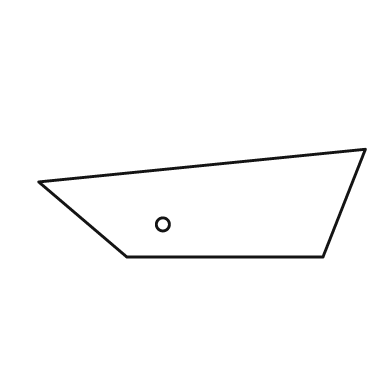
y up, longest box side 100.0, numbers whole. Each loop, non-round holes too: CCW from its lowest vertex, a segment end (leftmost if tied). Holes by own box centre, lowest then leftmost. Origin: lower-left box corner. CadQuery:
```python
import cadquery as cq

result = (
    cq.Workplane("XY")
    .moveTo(27.0, 0.0)
    .lineTo(87.0, 0.0)
    .lineTo(100.0, 33.0)
    .lineTo(0.0, 23.0)
    .close()
    .moveTo(38.0, 10.0)
    .circle(2.0)
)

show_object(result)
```